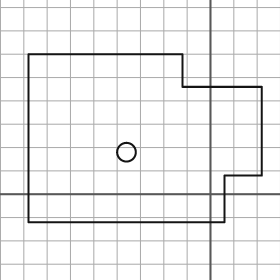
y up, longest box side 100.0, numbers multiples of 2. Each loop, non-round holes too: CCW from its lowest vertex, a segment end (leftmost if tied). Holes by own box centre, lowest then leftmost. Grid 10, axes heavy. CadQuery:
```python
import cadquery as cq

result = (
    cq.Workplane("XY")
    .moveTo(-78.0, -12.0)
    .lineTo(6.0, -12.0)
    .lineTo(6.0, 8.0)
    .lineTo(22.0, 8.0)
    .lineTo(22.0, 46.0)
    .lineTo(-12.0, 46.0)
    .lineTo(-12.0, 60.0)
    .lineTo(-78.0, 60.0)
    .close()
    .moveTo(-36.0, 18.0)
    .circle(4.0)
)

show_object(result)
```